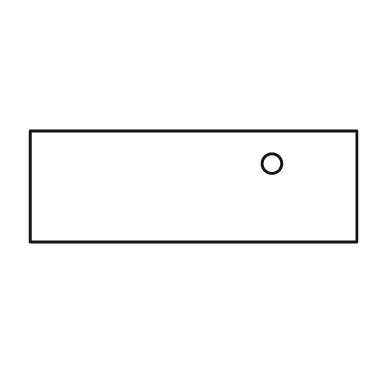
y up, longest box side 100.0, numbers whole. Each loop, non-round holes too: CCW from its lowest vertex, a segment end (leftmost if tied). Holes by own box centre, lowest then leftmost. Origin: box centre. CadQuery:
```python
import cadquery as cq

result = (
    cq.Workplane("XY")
    .moveTo(-50.0, -17.0)
    .lineTo(50.0, -17.0)
    .lineTo(50.0, 17.0)
    .lineTo(-50.0, 17.0)
    .close()
    .moveTo(24.0, 7.0)
    .circle(3.0)
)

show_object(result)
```